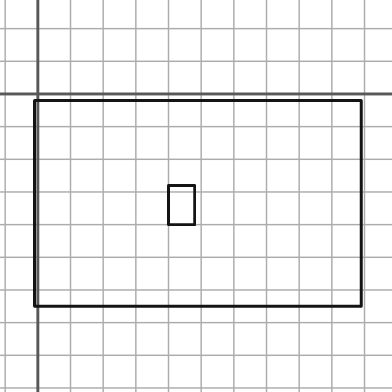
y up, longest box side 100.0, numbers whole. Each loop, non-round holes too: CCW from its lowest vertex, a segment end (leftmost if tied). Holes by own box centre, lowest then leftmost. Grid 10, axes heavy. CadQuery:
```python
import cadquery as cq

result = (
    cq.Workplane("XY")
    .moveTo(-1.0, -65.0)
    .lineTo(99.0, -65.0)
    .lineTo(99.0, -2.0)
    .lineTo(-1.0, -2.0)
    .close()
    .moveTo(40.0, -40.0)
    .lineTo(48.0, -40.0)
    .lineTo(48.0, -28.0)
    .lineTo(40.0, -28.0)
    .close()
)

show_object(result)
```